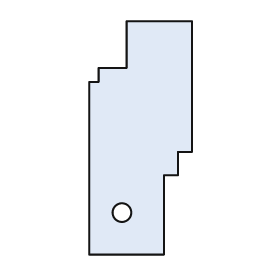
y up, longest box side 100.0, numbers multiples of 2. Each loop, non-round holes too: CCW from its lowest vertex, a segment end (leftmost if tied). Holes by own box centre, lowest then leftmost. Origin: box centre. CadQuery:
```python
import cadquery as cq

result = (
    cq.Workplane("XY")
    .moveTo(-22.0, -50.0)
    .lineTo(10.0, -50.0)
    .lineTo(10.0, -16.0)
    .lineTo(16.0, -16.0)
    .lineTo(16.0, -6.0)
    .lineTo(22.0, -6.0)
    .lineTo(22.0, 50.0)
    .lineTo(-6.0, 50.0)
    .lineTo(-6.0, 30.0)
    .lineTo(-18.0, 30.0)
    .lineTo(-18.0, 24.0)
    .lineTo(-22.0, 24.0)
    .close()
    .moveTo(-8.0, -32.0)
    .circle(4.0)
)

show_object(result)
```